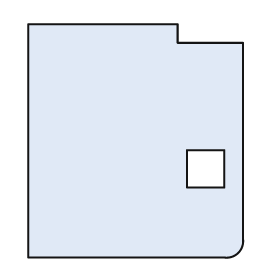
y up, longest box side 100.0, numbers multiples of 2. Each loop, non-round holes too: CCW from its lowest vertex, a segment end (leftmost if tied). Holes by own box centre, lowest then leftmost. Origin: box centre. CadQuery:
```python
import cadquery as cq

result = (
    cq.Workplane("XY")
    .moveTo(-46.0, -50.0)
    .lineTo(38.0, -50.0)
    .threePointArc((44.0, -48.0), (46.0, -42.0))
    .lineTo(46.0, 42.0)
    .lineTo(18.0, 42.0)
    .lineTo(18.0, 50.0)
    .lineTo(-46.0, 50.0)
    .close()
    .moveTo(22.0, -20.0)
    .lineTo(38.0, -20.0)
    .lineTo(38.0, -4.0)
    .lineTo(22.0, -4.0)
    .close()
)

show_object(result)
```